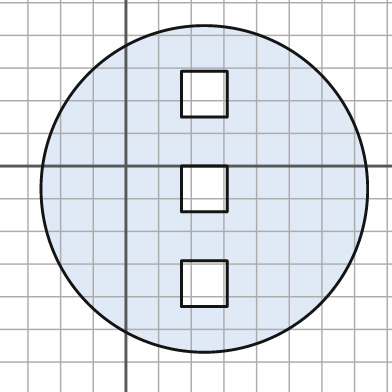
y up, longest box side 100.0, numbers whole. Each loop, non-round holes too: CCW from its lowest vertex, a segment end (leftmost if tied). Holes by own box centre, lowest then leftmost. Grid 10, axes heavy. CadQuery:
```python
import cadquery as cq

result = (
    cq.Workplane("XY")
    .moveTo(24.0, -7.0)
    .circle(50.0)
    .moveTo(17.0, -43.0)
    .lineTo(31.0, -43.0)
    .lineTo(31.0, -29.0)
    .lineTo(17.0, -29.0)
    .close()
    .moveTo(17.0, -14.0)
    .lineTo(31.0, -14.0)
    .lineTo(31.0, 0.0)
    .lineTo(17.0, 0.0)
    .close()
    .moveTo(17.0, 15.0)
    .lineTo(31.0, 15.0)
    .lineTo(31.0, 29.0)
    .lineTo(17.0, 29.0)
    .close()
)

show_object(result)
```